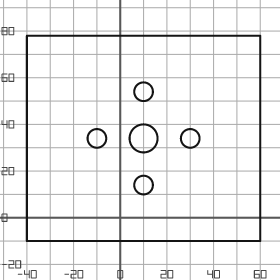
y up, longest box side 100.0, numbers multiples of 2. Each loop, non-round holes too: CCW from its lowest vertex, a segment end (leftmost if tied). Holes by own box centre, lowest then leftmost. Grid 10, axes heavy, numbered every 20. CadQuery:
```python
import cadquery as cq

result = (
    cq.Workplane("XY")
    .moveTo(-40.0, -10.0)
    .lineTo(60.0, -10.0)
    .lineTo(60.0, 78.0)
    .lineTo(-40.0, 78.0)
    .close()
    .moveTo(10.0, 14.0)
    .circle(4.0)
    .moveTo(-10.0, 34.0)
    .circle(4.0)
    .moveTo(10.0, 34.0)
    .circle(6.0)
    .moveTo(30.0, 34.0)
    .circle(4.0)
    .moveTo(10.0, 54.0)
    .circle(4.0)
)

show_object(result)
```